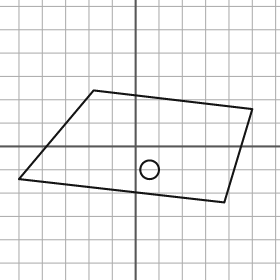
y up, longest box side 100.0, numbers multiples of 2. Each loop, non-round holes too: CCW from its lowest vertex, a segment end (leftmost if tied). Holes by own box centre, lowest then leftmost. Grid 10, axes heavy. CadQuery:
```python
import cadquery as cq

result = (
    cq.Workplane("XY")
    .moveTo(38.0, -24.0)
    .lineTo(50.0, 16.0)
    .lineTo(-18.0, 24.0)
    .lineTo(-50.0, -14.0)
    .close()
    .moveTo(6.0, -10.0)
    .circle(4.0)
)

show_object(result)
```